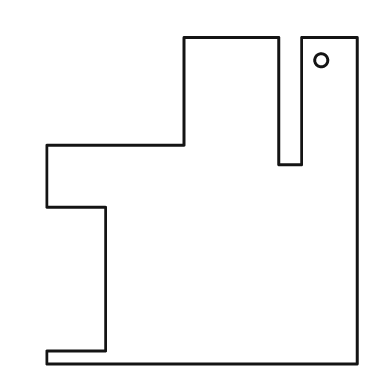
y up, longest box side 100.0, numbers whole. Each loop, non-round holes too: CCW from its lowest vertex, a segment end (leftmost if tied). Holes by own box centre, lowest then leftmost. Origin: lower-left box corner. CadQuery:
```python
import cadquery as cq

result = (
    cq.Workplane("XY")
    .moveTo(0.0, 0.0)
    .lineTo(95.0, 0.0)
    .lineTo(95.0, 100.0)
    .lineTo(78.0, 100.0)
    .lineTo(78.0, 61.0)
    .lineTo(71.0, 61.0)
    .lineTo(71.0, 100.0)
    .lineTo(42.0, 100.0)
    .lineTo(42.0, 67.0)
    .lineTo(0.0, 67.0)
    .lineTo(0.0, 48.0)
    .lineTo(18.0, 48.0)
    .lineTo(18.0, 4.0)
    .lineTo(0.0, 4.0)
    .close()
    .moveTo(84.0, 93.0)
    .circle(2.0)
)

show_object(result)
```